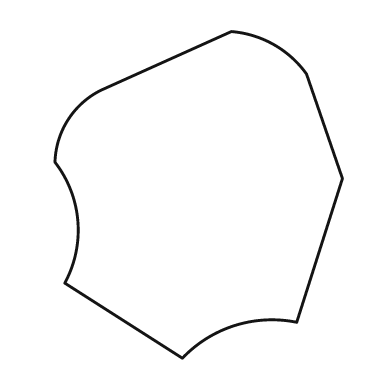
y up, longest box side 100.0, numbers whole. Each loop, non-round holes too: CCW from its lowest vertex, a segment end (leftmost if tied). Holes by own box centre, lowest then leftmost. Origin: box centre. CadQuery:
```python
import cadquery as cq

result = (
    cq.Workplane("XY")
    .moveTo(-5.0, -50.0)
    .threePointArc((11.0, -40.0), (30.0, -39.0))
    .lineTo(44.0, 5.0)
    .lineTo(33.0, 37.0)
    .threePointArc((23.0, 46.0), (10.0, 50.0))
    .lineTo(-30.0, 32.0)
    .threePointArc((-40.0, 23.0), (-44.0, 10.0))
    .threePointArc((-37.0, -8.0), (-41.0, -27.0))
    .close()
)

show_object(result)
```